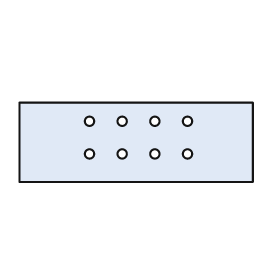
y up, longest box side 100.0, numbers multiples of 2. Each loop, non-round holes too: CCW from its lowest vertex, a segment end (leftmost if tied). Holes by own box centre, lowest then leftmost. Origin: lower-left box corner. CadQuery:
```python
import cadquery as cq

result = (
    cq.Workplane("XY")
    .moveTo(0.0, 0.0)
    .lineTo(100.0, 0.0)
    .lineTo(100.0, 34.0)
    .lineTo(0.0, 34.0)
    .close()
    .moveTo(30.0, 12.0)
    .circle(2.0)
    .moveTo(44.0, 12.0)
    .circle(2.0)
    .moveTo(58.0, 12.0)
    .circle(2.0)
    .moveTo(72.0, 12.0)
    .circle(2.0)
    .moveTo(30.0, 26.0)
    .circle(2.0)
    .moveTo(44.0, 26.0)
    .circle(2.0)
    .moveTo(58.0, 26.0)
    .circle(2.0)
    .moveTo(72.0, 26.0)
    .circle(2.0)
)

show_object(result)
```